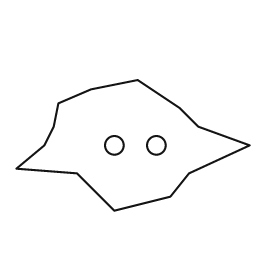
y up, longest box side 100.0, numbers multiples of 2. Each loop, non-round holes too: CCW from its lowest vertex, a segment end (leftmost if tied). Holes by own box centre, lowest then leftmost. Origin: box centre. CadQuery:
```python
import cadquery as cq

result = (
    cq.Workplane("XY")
    .moveTo(-8.0, -28.0)
    .lineTo(16.0, -22.0)
    .lineTo(24.0, -12.0)
    .lineTo(50.0, 0.0)
    .lineTo(28.0, 8.0)
    .lineTo(20.0, 16.0)
    .lineTo(2.0, 28.0)
    .lineTo(-18.0, 24.0)
    .lineTo(-32.0, 18.0)
    .lineTo(-34.0, 8.0)
    .lineTo(-38.0, 0.0)
    .lineTo(-50.0, -10.0)
    .lineTo(-24.0, -12.0)
    .close()
    .moveTo(-8.0, 0.0)
    .circle(4.0)
    .moveTo(10.0, 0.0)
    .circle(4.0)
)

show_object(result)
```